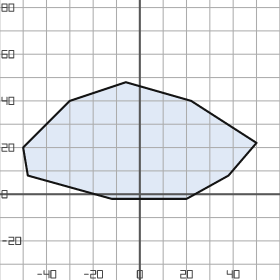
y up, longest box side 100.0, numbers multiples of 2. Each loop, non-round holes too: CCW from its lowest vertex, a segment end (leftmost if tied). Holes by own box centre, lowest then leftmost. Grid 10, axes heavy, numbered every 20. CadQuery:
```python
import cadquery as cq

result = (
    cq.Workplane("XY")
    .moveTo(-12.0, -2.0)
    .lineTo(20.0, -2.0)
    .lineTo(38.0, 8.0)
    .lineTo(50.0, 22.0)
    .lineTo(22.0, 40.0)
    .lineTo(-6.0, 48.0)
    .lineTo(-30.0, 40.0)
    .lineTo(-50.0, 20.0)
    .lineTo(-48.0, 8.0)
    .close()
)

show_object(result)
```